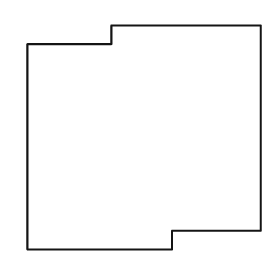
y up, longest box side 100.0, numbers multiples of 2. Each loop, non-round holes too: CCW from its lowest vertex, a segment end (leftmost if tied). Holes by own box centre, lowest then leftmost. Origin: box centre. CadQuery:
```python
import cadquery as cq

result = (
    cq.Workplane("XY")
    .moveTo(-50.0, -48.0)
    .lineTo(12.0, -48.0)
    .lineTo(12.0, -40.0)
    .lineTo(50.0, -40.0)
    .lineTo(50.0, 48.0)
    .lineTo(-14.0, 48.0)
    .lineTo(-14.0, 40.0)
    .lineTo(-50.0, 40.0)
    .close()
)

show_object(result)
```